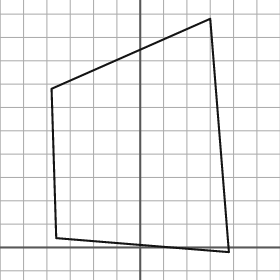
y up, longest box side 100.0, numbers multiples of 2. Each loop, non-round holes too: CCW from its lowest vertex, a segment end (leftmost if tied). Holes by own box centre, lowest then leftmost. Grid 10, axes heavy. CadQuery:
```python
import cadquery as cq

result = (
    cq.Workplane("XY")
    .moveTo(38.0, -2.0)
    .lineTo(30.0, 98.0)
    .lineTo(-38.0, 68.0)
    .lineTo(-36.0, 4.0)
    .close()
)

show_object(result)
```